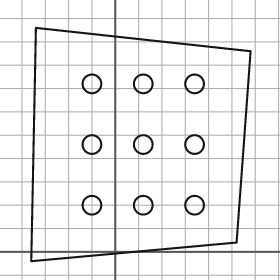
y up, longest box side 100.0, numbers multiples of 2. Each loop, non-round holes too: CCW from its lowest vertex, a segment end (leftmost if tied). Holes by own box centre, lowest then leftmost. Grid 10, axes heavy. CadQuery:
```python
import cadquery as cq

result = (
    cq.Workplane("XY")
    .moveTo(-36.0, -4.0)
    .lineTo(52.0, 4.0)
    .lineTo(58.0, 86.0)
    .lineTo(-34.0, 96.0)
    .close()
    .moveTo(-10.0, 20.0)
    .circle(4.0)
    .moveTo(12.0, 20.0)
    .circle(4.0)
    .moveTo(34.0, 20.0)
    .circle(4.0)
    .moveTo(-10.0, 46.0)
    .circle(4.0)
    .moveTo(12.0, 46.0)
    .circle(4.0)
    .moveTo(34.0, 46.0)
    .circle(4.0)
    .moveTo(-10.0, 72.0)
    .circle(4.0)
    .moveTo(12.0, 72.0)
    .circle(4.0)
    .moveTo(34.0, 72.0)
    .circle(4.0)
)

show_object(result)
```